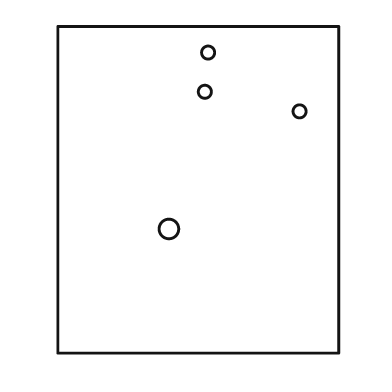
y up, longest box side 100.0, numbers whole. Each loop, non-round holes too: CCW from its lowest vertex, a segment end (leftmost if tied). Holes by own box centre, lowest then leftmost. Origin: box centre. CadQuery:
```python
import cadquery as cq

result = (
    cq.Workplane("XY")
    .moveTo(-43.0, -50.0)
    .lineTo(43.0, -50.0)
    .lineTo(43.0, 50.0)
    .lineTo(-43.0, 50.0)
    .close()
    .moveTo(-9.0, -12.0)
    .circle(3.0)
    .moveTo(31.0, 24.0)
    .circle(2.0)
    .moveTo(2.0, 30.0)
    .circle(2.0)
    .moveTo(3.0, 42.0)
    .circle(2.0)
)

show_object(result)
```